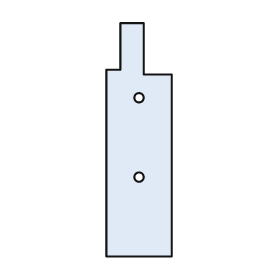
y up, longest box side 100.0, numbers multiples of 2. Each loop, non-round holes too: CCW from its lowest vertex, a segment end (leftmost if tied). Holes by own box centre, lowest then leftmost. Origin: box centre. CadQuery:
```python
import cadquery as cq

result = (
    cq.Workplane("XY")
    .moveTo(-14.0, -50.0)
    .lineTo(14.0, -50.0)
    .lineTo(14.0, 28.0)
    .lineTo(2.0, 28.0)
    .lineTo(2.0, 50.0)
    .lineTo(-8.0, 50.0)
    .lineTo(-8.0, 30.0)
    .lineTo(-14.0, 30.0)
    .close()
    .moveTo(0.0, -16.0)
    .circle(2.0)
    .moveTo(0.0, 18.0)
    .circle(2.0)
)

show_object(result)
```